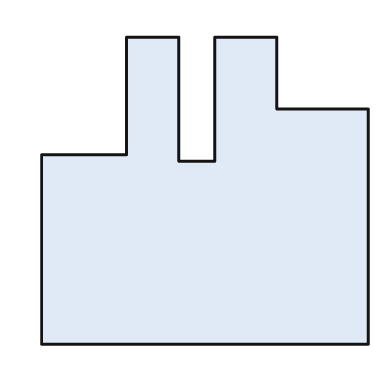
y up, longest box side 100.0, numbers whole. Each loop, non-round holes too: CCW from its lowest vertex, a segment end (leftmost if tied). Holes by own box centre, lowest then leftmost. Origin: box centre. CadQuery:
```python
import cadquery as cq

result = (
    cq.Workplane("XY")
    .moveTo(-50.0, -47.0)
    .lineTo(50.0, -47.0)
    .lineTo(50.0, 25.0)
    .lineTo(22.0, 25.0)
    .lineTo(22.0, 47.0)
    .lineTo(3.0, 47.0)
    .lineTo(3.0, 9.0)
    .lineTo(-8.0, 9.0)
    .lineTo(-8.0, 47.0)
    .lineTo(-24.0, 47.0)
    .lineTo(-24.0, 11.0)
    .lineTo(-50.0, 11.0)
    .close()
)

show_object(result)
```